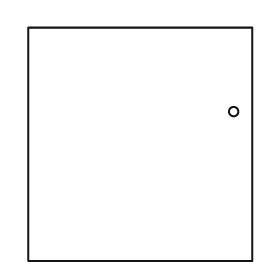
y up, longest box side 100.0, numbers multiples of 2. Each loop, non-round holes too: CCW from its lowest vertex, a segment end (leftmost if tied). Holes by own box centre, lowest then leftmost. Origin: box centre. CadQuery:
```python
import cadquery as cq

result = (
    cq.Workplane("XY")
    .moveTo(-48.0, -50.0)
    .lineTo(48.0, -50.0)
    .lineTo(48.0, 50.0)
    .lineTo(-48.0, 50.0)
    .close()
    .moveTo(40.0, 14.0)
    .circle(2.0)
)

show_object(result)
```